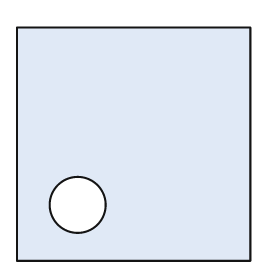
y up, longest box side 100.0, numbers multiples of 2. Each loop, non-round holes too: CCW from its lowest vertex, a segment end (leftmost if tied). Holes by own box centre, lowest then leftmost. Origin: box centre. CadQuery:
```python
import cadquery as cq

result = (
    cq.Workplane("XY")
    .moveTo(-50.0, -50.0)
    .lineTo(50.0, -50.0)
    .lineTo(50.0, 50.0)
    .lineTo(-50.0, 50.0)
    .close()
    .moveTo(-24.0, -26.0)
    .circle(12.0)
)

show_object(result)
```